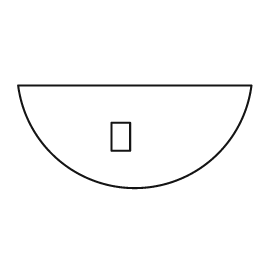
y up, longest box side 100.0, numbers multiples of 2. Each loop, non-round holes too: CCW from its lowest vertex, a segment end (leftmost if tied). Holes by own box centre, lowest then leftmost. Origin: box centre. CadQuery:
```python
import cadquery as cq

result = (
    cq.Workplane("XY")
    .moveTo(-50.0, 22.0)
    .threePointArc((0.0, -22.0), (50.0, 22.0))
    .close()
    .moveTo(-10.0, -6.0)
    .lineTo(-2.0, -6.0)
    .lineTo(-2.0, 6.0)
    .lineTo(-10.0, 6.0)
    .close()
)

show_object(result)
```